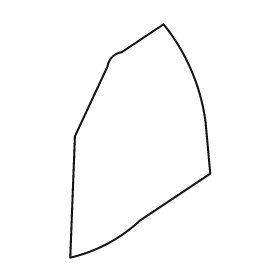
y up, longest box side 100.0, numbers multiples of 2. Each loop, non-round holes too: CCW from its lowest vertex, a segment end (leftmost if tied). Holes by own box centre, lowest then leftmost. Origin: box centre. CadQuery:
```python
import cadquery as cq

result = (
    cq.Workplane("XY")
    .moveTo(-30.0, -50.0)
    .threePointArc((-14.0, -44.0), (0.0, -34.0))
    .lineTo(30.0, -14.0)
    .lineTo(28.0, 8.0)
    .threePointArc((22.0, 30.0), (10.0, 50.0))
    .lineTo(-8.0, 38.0)
    .threePointArc((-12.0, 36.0), (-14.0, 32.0))
    .lineTo(-28.0, 2.0)
    .close()
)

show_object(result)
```